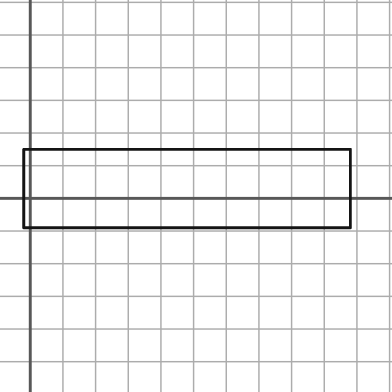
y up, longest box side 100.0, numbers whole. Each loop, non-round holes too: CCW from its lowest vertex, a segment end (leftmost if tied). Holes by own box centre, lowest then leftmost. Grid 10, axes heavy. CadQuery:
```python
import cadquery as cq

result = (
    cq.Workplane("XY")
    .moveTo(-2.0, -9.0)
    .lineTo(98.0, -9.0)
    .lineTo(98.0, 15.0)
    .lineTo(-2.0, 15.0)
    .close()
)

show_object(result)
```